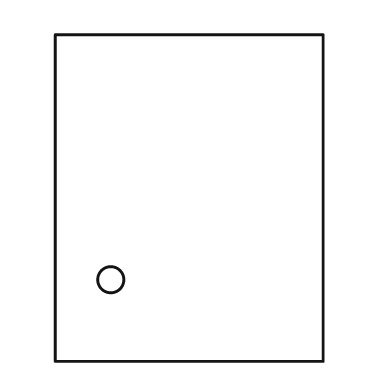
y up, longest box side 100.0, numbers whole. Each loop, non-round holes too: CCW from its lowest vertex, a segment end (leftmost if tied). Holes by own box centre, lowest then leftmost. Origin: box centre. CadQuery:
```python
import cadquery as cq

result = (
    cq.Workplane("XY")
    .moveTo(-41.0, -50.0)
    .lineTo(41.0, -50.0)
    .lineTo(41.0, 50.0)
    .lineTo(-41.0, 50.0)
    .close()
    .moveTo(-24.0, -25.0)
    .circle(4.0)
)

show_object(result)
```